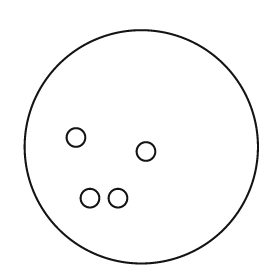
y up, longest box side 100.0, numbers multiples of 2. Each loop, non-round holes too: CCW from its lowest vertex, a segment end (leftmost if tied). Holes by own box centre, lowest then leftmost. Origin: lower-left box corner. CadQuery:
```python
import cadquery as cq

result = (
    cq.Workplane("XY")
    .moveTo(50.0, 50.0)
    .circle(50.0)
    .moveTo(28.0, 28.0)
    .circle(4.0)
    .moveTo(40.0, 28.0)
    .circle(4.0)
    .moveTo(52.0, 48.0)
    .circle(4.0)
    .moveTo(22.0, 54.0)
    .circle(4.0)
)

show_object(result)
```